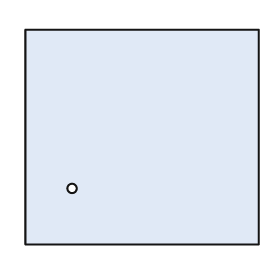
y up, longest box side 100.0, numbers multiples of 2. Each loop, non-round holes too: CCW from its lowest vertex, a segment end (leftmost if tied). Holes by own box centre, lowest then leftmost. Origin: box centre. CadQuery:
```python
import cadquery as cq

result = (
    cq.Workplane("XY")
    .moveTo(-50.0, -46.0)
    .lineTo(50.0, -46.0)
    .lineTo(50.0, 46.0)
    .lineTo(-50.0, 46.0)
    .close()
    .moveTo(-30.0, -22.0)
    .circle(2.0)
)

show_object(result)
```